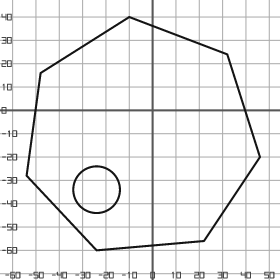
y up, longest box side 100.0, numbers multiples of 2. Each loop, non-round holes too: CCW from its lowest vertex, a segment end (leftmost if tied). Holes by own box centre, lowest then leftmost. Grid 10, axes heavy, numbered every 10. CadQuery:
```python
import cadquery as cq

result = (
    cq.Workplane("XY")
    .moveTo(-24.0, -60.0)
    .lineTo(22.0, -56.0)
    .lineTo(46.0, -20.0)
    .lineTo(32.0, 24.0)
    .lineTo(-10.0, 40.0)
    .lineTo(-48.0, 16.0)
    .lineTo(-54.0, -28.0)
    .close()
    .moveTo(-24.0, -34.0)
    .circle(10.0)
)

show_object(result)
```